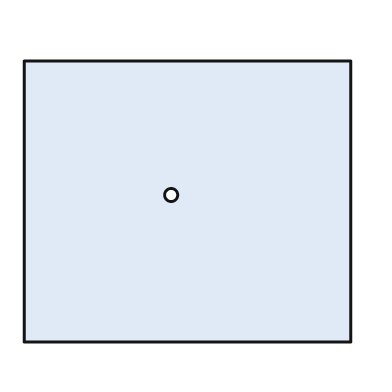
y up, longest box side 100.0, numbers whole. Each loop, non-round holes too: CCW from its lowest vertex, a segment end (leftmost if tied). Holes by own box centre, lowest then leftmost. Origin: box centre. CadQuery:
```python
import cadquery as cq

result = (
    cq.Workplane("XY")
    .moveTo(-50.0, -43.0)
    .lineTo(50.0, -43.0)
    .lineTo(50.0, 43.0)
    .lineTo(-50.0, 43.0)
    .close()
    .moveTo(-5.0, 2.0)
    .circle(2.0)
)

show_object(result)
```